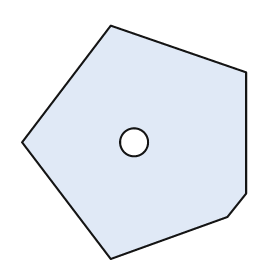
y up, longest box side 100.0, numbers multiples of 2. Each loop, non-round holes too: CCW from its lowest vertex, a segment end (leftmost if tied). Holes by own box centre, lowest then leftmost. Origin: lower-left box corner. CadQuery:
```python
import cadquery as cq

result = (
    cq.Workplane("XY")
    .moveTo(38.0, 0.0)
    .lineTo(88.0, 18.0)
    .lineTo(96.0, 28.0)
    .lineTo(96.0, 80.0)
    .lineTo(38.0, 100.0)
    .lineTo(0.0, 50.0)
    .close()
    .moveTo(48.0, 50.0)
    .circle(6.0)
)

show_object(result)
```